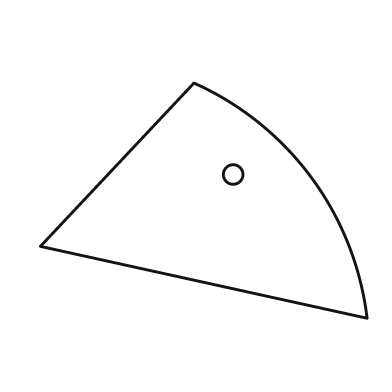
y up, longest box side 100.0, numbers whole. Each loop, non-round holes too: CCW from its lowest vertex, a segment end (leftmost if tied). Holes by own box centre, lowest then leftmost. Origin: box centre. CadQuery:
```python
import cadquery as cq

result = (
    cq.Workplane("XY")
    .moveTo(50.0, -36.0)
    .threePointArc((33.0, 7.0), (-3.0, 36.0))
    .lineTo(-50.0, -14.0)
    .close()
    .moveTo(9.0, 8.0)
    .circle(3.0)
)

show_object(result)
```